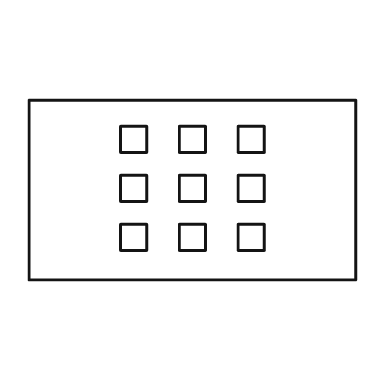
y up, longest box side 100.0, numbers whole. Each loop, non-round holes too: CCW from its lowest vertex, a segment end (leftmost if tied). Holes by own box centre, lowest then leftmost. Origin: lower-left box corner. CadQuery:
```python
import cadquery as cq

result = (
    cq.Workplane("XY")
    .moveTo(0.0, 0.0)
    .lineTo(100.0, 0.0)
    .lineTo(100.0, 55.0)
    .lineTo(0.0, 55.0)
    .close()
    .moveTo(28.0, 9.0)
    .lineTo(36.0, 9.0)
    .lineTo(36.0, 17.0)
    .lineTo(28.0, 17.0)
    .close()
    .moveTo(46.0, 9.0)
    .lineTo(54.0, 9.0)
    .lineTo(54.0, 17.0)
    .lineTo(46.0, 17.0)
    .close()
    .moveTo(64.0, 9.0)
    .lineTo(72.0, 9.0)
    .lineTo(72.0, 17.0)
    .lineTo(64.0, 17.0)
    .close()
    .moveTo(28.0, 24.0)
    .lineTo(36.0, 24.0)
    .lineTo(36.0, 32.0)
    .lineTo(28.0, 32.0)
    .close()
    .moveTo(46.0, 24.0)
    .lineTo(54.0, 24.0)
    .lineTo(54.0, 32.0)
    .lineTo(46.0, 32.0)
    .close()
    .moveTo(64.0, 24.0)
    .lineTo(72.0, 24.0)
    .lineTo(72.0, 32.0)
    .lineTo(64.0, 32.0)
    .close()
    .moveTo(28.0, 39.0)
    .lineTo(36.0, 39.0)
    .lineTo(36.0, 47.0)
    .lineTo(28.0, 47.0)
    .close()
    .moveTo(46.0, 39.0)
    .lineTo(54.0, 39.0)
    .lineTo(54.0, 47.0)
    .lineTo(46.0, 47.0)
    .close()
    .moveTo(64.0, 39.0)
    .lineTo(72.0, 39.0)
    .lineTo(72.0, 47.0)
    .lineTo(64.0, 47.0)
    .close()
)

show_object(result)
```